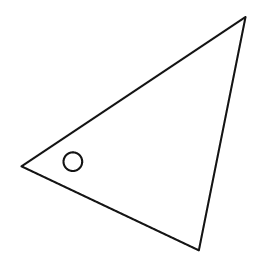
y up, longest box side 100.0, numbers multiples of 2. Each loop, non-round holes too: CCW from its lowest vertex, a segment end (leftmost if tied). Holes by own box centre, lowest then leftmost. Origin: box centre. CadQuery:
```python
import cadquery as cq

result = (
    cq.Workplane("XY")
    .moveTo(28.0, -50.0)
    .lineTo(48.0, 50.0)
    .lineTo(-48.0, -14.0)
    .close()
    .moveTo(-26.0, -12.0)
    .circle(4.0)
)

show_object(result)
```